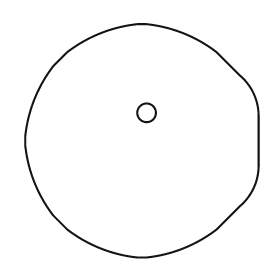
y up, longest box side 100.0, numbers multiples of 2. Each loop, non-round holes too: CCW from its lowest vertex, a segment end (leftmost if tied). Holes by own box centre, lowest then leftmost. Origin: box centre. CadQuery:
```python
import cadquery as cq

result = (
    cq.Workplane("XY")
    .moveTo(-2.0, -50.0)
    .lineTo(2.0, -50.0)
    .threePointArc((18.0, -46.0), (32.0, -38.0))
    .lineTo(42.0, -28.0)
    .threePointArc((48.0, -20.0), (50.0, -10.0))
    .lineTo(50.0, 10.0)
    .threePointArc((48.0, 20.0), (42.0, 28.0))
    .lineTo(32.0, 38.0)
    .threePointArc((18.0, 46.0), (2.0, 50.0))
    .lineTo(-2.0, 50.0)
    .threePointArc((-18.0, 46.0), (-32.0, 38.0))
    .lineTo(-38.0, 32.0)
    .threePointArc((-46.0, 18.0), (-50.0, 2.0))
    .lineTo(-50.0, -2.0)
    .threePointArc((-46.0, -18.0), (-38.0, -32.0))
    .lineTo(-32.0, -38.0)
    .threePointArc((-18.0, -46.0), (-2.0, -50.0))
    .close()
    .moveTo(2.0, 12.0)
    .circle(4.0)
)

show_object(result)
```